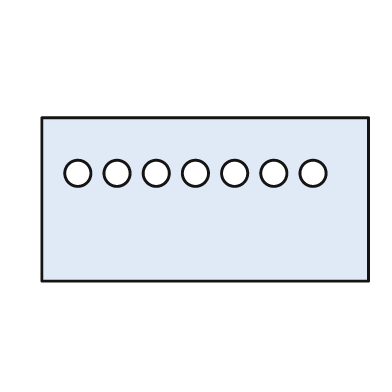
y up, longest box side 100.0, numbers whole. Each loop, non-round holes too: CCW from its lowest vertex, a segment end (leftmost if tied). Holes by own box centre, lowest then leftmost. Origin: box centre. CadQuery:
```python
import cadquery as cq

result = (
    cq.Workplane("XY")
    .moveTo(-50.0, -25.0)
    .lineTo(50.0, -25.0)
    .lineTo(50.0, 25.0)
    .lineTo(-50.0, 25.0)
    .close()
    .moveTo(-39.0, 8.0)
    .circle(4.0)
    .moveTo(-27.0, 8.0)
    .circle(4.0)
    .moveTo(-15.0, 8.0)
    .circle(4.0)
    .moveTo(-3.0, 8.0)
    .circle(4.0)
    .moveTo(9.0, 8.0)
    .circle(4.0)
    .moveTo(21.0, 8.0)
    .circle(4.0)
    .moveTo(33.0, 8.0)
    .circle(4.0)
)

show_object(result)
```